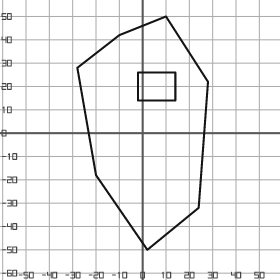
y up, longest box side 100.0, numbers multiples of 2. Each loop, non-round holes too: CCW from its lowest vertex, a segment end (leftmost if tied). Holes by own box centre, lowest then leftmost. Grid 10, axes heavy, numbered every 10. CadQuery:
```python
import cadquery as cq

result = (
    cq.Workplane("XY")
    .moveTo(2.0, -50.0)
    .lineTo(24.0, -32.0)
    .lineTo(28.0, 22.0)
    .lineTo(10.0, 50.0)
    .lineTo(-10.0, 42.0)
    .lineTo(-28.0, 28.0)
    .lineTo(-20.0, -18.0)
    .close()
    .moveTo(-2.0, 14.0)
    .lineTo(14.0, 14.0)
    .lineTo(14.0, 26.0)
    .lineTo(-2.0, 26.0)
    .close()
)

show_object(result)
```